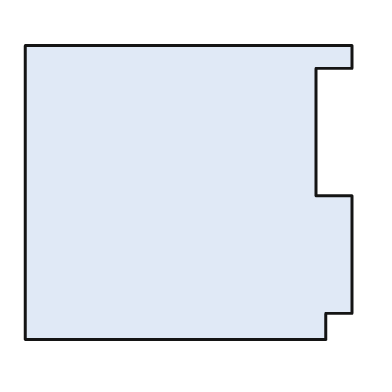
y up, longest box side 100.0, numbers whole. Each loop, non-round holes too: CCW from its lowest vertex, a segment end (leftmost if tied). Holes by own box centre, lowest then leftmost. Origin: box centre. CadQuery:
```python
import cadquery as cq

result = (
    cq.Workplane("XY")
    .moveTo(-50.0, -45.0)
    .lineTo(42.0, -45.0)
    .lineTo(42.0, -37.0)
    .lineTo(50.0, -37.0)
    .lineTo(50.0, -1.0)
    .lineTo(39.0, -1.0)
    .lineTo(39.0, 38.0)
    .lineTo(50.0, 38.0)
    .lineTo(50.0, 45.0)
    .lineTo(-50.0, 45.0)
    .close()
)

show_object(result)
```